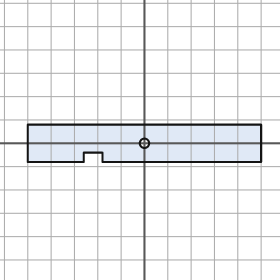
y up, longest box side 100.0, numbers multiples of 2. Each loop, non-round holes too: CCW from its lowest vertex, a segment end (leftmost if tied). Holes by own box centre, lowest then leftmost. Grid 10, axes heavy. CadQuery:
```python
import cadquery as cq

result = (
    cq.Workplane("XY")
    .moveTo(-50.0, -8.0)
    .lineTo(-26.0, -8.0)
    .lineTo(-26.0, -4.0)
    .lineTo(-18.0, -4.0)
    .lineTo(-18.0, -8.0)
    .lineTo(50.0, -8.0)
    .lineTo(50.0, 8.0)
    .lineTo(-50.0, 8.0)
    .close()
    .moveTo(0.0, 0.0)
    .circle(2.0)
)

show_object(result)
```